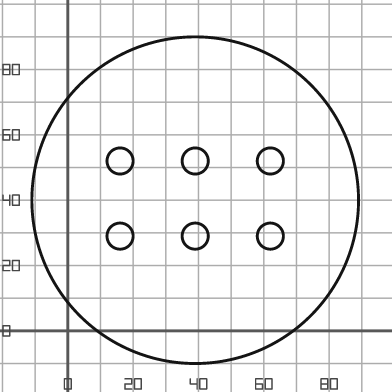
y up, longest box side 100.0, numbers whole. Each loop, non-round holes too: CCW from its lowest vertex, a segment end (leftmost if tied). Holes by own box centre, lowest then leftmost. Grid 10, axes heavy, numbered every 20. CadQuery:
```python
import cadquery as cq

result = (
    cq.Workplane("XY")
    .moveTo(39.0, 40.0)
    .circle(50.0)
    .moveTo(16.0, 29.0)
    .circle(4.0)
    .moveTo(39.0, 29.0)
    .circle(4.0)
    .moveTo(62.0, 29.0)
    .circle(4.0)
    .moveTo(16.0, 52.0)
    .circle(4.0)
    .moveTo(39.0, 52.0)
    .circle(4.0)
    .moveTo(62.0, 52.0)
    .circle(4.0)
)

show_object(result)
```